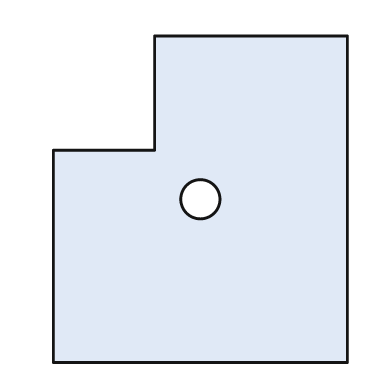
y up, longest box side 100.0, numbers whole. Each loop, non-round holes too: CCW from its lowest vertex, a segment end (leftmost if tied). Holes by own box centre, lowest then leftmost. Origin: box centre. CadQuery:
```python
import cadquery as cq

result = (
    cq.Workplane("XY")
    .moveTo(-45.0, -50.0)
    .lineTo(45.0, -50.0)
    .lineTo(45.0, 50.0)
    .lineTo(-14.0, 50.0)
    .lineTo(-14.0, 15.0)
    .lineTo(-45.0, 15.0)
    .close()
    .moveTo(0.0, 0.0)
    .circle(6.0)
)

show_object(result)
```